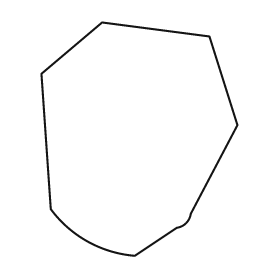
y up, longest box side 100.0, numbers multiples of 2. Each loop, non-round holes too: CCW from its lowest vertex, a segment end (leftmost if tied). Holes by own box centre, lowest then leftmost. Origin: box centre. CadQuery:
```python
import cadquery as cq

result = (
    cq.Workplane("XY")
    .moveTo(-2.0, -50.0)
    .lineTo(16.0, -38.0)
    .threePointArc((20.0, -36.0), (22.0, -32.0))
    .lineTo(42.0, 6.0)
    .lineTo(30.0, 44.0)
    .lineTo(-16.0, 50.0)
    .lineTo(-42.0, 28.0)
    .lineTo(-38.0, -30.0)
    .threePointArc((-22.0, -44.0), (-2.0, -50.0))
    .close()
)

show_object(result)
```